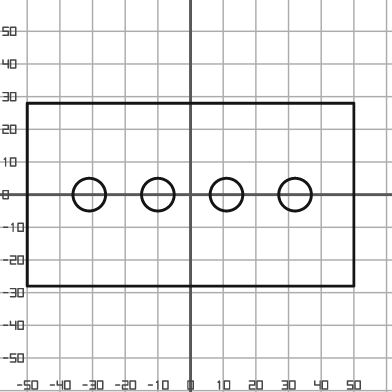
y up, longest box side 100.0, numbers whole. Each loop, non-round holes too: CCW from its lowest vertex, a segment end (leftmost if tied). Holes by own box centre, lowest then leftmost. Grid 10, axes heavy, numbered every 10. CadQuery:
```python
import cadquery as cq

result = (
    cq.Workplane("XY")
    .moveTo(-50.0, -28.0)
    .lineTo(50.0, -28.0)
    .lineTo(50.0, 28.0)
    .lineTo(-50.0, 28.0)
    .close()
    .moveTo(-31.0, 0.0)
    .circle(5.0)
    .moveTo(-10.0, 0.0)
    .circle(5.0)
    .moveTo(11.0, 0.0)
    .circle(5.0)
    .moveTo(32.0, 0.0)
    .circle(5.0)
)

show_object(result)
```